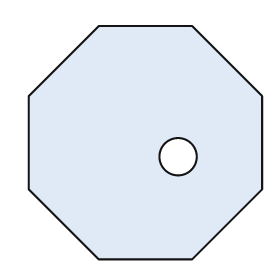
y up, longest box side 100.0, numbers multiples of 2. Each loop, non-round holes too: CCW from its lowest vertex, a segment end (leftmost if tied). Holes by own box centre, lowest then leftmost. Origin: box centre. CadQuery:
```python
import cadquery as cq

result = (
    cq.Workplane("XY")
    .moveTo(-20.0, -50.0)
    .lineTo(20.0, -50.0)
    .lineTo(50.0, -20.0)
    .lineTo(50.0, 20.0)
    .lineTo(20.0, 50.0)
    .lineTo(-20.0, 50.0)
    .lineTo(-50.0, 20.0)
    .lineTo(-50.0, -20.0)
    .close()
    .moveTo(14.0, -6.0)
    .circle(8.0)
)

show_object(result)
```